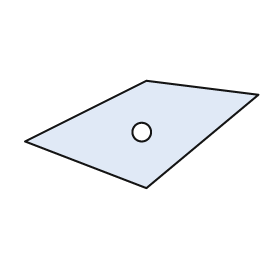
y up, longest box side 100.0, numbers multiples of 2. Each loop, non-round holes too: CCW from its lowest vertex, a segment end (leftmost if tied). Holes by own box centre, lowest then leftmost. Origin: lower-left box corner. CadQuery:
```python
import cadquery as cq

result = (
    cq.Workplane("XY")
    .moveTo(52.0, 0.0)
    .lineTo(100.0, 40.0)
    .lineTo(52.0, 46.0)
    .lineTo(0.0, 20.0)
    .close()
    .moveTo(50.0, 24.0)
    .circle(4.0)
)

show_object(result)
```